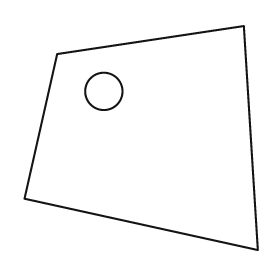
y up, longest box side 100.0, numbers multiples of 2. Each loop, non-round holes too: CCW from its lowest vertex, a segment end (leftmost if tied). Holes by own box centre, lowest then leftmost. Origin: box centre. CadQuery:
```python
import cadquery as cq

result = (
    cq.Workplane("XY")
    .moveTo(50.0, -48.0)
    .lineTo(44.0, 48.0)
    .lineTo(-36.0, 36.0)
    .lineTo(-50.0, -26.0)
    .close()
    .moveTo(-16.0, 20.0)
    .circle(8.0)
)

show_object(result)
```